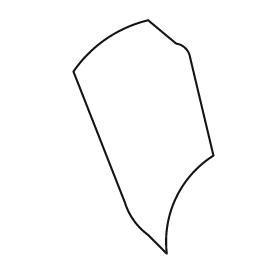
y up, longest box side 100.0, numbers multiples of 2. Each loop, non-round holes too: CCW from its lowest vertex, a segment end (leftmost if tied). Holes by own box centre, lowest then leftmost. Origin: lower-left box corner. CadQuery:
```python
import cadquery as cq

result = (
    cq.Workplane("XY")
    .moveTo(40.0, 0.0)
    .threePointArc((44.0, 24.0), (60.0, 42.0))
    .lineTo(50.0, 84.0)
    .threePointArc((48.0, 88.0), (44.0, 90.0))
    .lineTo(32.0, 100.0)
    .threePointArc((14.0, 92.0), (0.0, 78.0))
    .lineTo(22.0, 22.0)
    .threePointArc((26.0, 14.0), (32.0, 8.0))
    .close()
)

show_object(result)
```